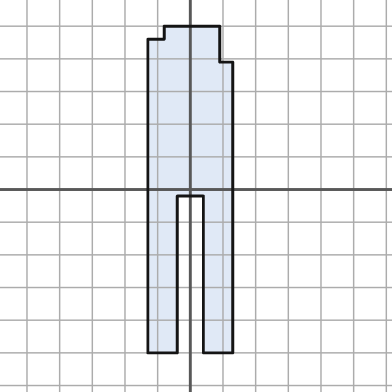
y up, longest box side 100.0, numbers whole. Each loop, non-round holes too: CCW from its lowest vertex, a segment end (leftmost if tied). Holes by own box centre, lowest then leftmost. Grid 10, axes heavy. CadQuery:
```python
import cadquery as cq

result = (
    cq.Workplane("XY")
    .moveTo(-13.0, -50.0)
    .lineTo(-4.0, -50.0)
    .lineTo(-4.0, -2.0)
    .lineTo(4.0, -2.0)
    .lineTo(4.0, -50.0)
    .lineTo(13.0, -50.0)
    .lineTo(13.0, 39.0)
    .lineTo(9.0, 39.0)
    .lineTo(9.0, 50.0)
    .lineTo(-8.0, 50.0)
    .lineTo(-8.0, 46.0)
    .lineTo(-13.0, 46.0)
    .close()
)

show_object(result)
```